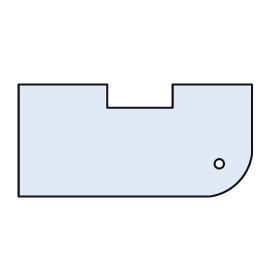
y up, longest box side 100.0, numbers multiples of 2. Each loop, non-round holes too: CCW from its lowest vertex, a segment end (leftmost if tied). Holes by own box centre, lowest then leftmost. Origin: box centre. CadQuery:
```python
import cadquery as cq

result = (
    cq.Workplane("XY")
    .moveTo(-50.0, -24.0)
    .lineTo(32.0, -24.0)
    .threePointArc((44.0, -18.0), (50.0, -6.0))
    .lineTo(50.0, 24.0)
    .lineTo(16.0, 24.0)
    .lineTo(16.0, 14.0)
    .lineTo(-12.0, 14.0)
    .lineTo(-12.0, 24.0)
    .lineTo(-50.0, 24.0)
    .close()
    .moveTo(36.0, -10.0)
    .circle(2.0)
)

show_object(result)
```